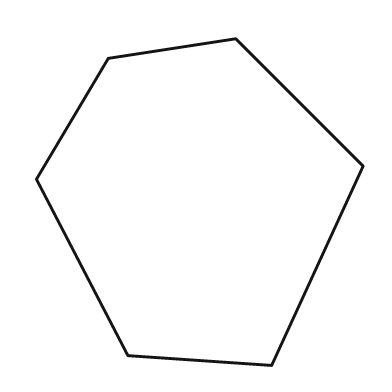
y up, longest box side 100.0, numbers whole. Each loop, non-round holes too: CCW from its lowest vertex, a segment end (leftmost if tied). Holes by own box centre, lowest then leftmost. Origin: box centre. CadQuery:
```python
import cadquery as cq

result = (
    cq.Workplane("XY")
    .moveTo(22.0, -50.0)
    .lineTo(50.0, 11.0)
    .lineTo(11.0, 50.0)
    .lineTo(-28.0, 44.0)
    .lineTo(-50.0, 7.0)
    .lineTo(-22.0, -47.0)
    .close()
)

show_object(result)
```